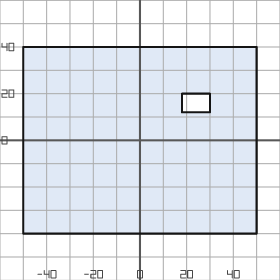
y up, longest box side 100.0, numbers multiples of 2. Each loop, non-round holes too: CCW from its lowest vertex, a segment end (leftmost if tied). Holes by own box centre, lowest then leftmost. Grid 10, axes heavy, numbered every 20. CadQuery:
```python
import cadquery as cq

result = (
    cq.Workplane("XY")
    .moveTo(-50.0, -40.0)
    .lineTo(50.0, -40.0)
    .lineTo(50.0, 40.0)
    .lineTo(-50.0, 40.0)
    .close()
    .moveTo(18.0, 12.0)
    .lineTo(30.0, 12.0)
    .lineTo(30.0, 20.0)
    .lineTo(18.0, 20.0)
    .close()
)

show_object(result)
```